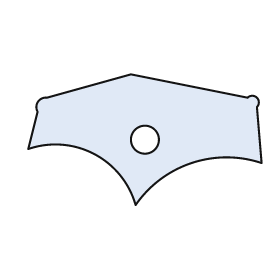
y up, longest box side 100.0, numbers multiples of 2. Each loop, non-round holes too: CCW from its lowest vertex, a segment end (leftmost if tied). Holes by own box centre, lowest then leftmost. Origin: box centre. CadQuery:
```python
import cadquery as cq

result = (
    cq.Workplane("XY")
    .moveTo(-4.0, -28.0)
    .threePointArc((20.0, -10.0), (50.0, -10.0))
    .lineTo(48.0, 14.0)
    .threePointArc((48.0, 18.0), (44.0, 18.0))
    .lineTo(-6.0, 28.0)
    .lineTo(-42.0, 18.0)
    .threePointArc((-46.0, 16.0), (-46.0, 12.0))
    .lineTo(-50.0, -4.0)
    .threePointArc((-22.0, -6.0), (-4.0, -28.0))
    .close()
    .moveTo(0.0, 0.0)
    .circle(6.0)
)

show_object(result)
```